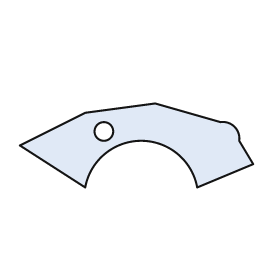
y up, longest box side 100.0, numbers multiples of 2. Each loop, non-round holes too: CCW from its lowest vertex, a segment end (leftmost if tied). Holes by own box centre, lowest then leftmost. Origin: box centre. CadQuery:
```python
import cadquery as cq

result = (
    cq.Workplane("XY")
    .moveTo(-22.0, -18.0)
    .threePointArc((2.0, 2.0), (26.0, -18.0))
    .lineTo(50.0, -8.0)
    .lineTo(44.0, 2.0)
    .threePointArc((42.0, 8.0), (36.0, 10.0))
    .lineTo(8.0, 18.0)
    .lineTo(-22.0, 14.0)
    .lineTo(-50.0, 0.0)
    .close()
    .moveTo(-14.0, 6.0)
    .circle(4.0)
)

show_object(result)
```